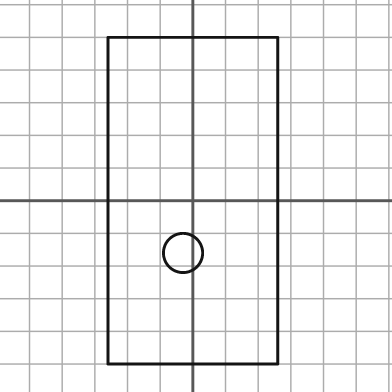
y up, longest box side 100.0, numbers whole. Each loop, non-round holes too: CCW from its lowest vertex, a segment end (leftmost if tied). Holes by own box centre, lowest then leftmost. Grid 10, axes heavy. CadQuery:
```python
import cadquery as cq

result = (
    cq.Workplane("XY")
    .moveTo(-26.0, -50.0)
    .lineTo(26.0, -50.0)
    .lineTo(26.0, 50.0)
    .lineTo(-26.0, 50.0)
    .close()
    .moveTo(-3.0, -16.0)
    .circle(6.0)
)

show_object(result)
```